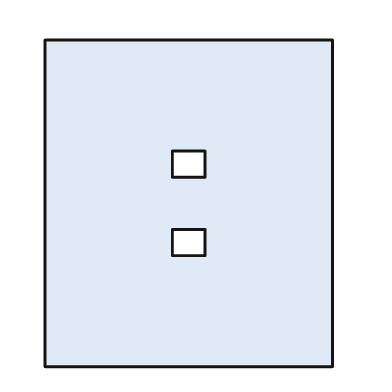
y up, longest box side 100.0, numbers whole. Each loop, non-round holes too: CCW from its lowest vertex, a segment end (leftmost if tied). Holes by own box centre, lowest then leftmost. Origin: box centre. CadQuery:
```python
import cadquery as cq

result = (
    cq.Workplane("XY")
    .moveTo(-44.0, -50.0)
    .lineTo(44.0, -50.0)
    .lineTo(44.0, 50.0)
    .lineTo(-44.0, 50.0)
    .close()
    .moveTo(-5.0, -16.0)
    .lineTo(5.0, -16.0)
    .lineTo(5.0, -8.0)
    .lineTo(-5.0, -8.0)
    .close()
    .moveTo(-5.0, 8.0)
    .lineTo(5.0, 8.0)
    .lineTo(5.0, 16.0)
    .lineTo(-5.0, 16.0)
    .close()
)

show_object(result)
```